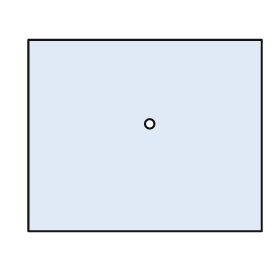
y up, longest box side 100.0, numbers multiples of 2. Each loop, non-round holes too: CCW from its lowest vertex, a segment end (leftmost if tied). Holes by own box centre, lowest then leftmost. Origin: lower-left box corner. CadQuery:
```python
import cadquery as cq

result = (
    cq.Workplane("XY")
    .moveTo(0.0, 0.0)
    .lineTo(100.0, 0.0)
    .lineTo(100.0, 82.0)
    .lineTo(0.0, 82.0)
    .close()
    .moveTo(52.0, 46.0)
    .circle(2.0)
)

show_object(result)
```